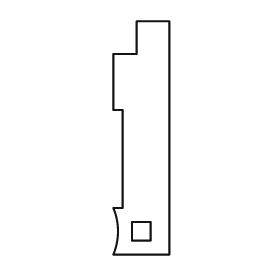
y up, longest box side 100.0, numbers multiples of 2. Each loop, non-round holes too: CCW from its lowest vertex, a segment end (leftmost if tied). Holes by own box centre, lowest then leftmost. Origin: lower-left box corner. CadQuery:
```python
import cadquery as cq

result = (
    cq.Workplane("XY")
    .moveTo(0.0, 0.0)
    .lineTo(24.0, 0.0)
    .lineTo(24.0, 100.0)
    .lineTo(10.0, 100.0)
    .lineTo(10.0, 86.0)
    .lineTo(0.0, 86.0)
    .lineTo(0.0, 62.0)
    .lineTo(4.0, 62.0)
    .lineTo(4.0, 20.0)
    .lineTo(0.0, 20.0)
    .threePointArc((2.0, 10.0), (0.0, 0.0))
    .close()
    .moveTo(8.0, 6.0)
    .lineTo(16.0, 6.0)
    .lineTo(16.0, 14.0)
    .lineTo(8.0, 14.0)
    .close()
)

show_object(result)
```